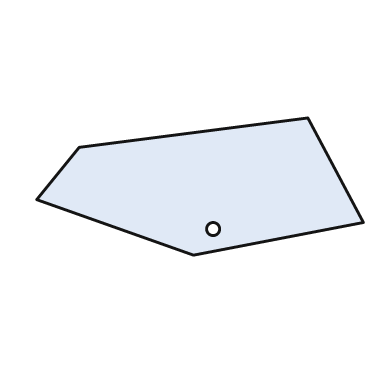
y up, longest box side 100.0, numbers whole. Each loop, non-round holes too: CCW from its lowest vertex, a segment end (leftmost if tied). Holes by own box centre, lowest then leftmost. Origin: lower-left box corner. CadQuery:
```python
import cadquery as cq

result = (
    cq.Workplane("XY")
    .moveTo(48.0, 0.0)
    .lineTo(100.0, 10.0)
    .lineTo(83.0, 42.0)
    .lineTo(13.0, 33.0)
    .lineTo(0.0, 17.0)
    .close()
    .moveTo(54.0, 8.0)
    .circle(2.0)
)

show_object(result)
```